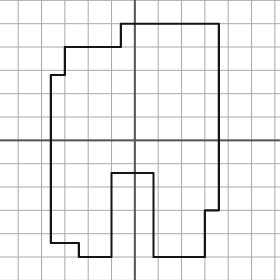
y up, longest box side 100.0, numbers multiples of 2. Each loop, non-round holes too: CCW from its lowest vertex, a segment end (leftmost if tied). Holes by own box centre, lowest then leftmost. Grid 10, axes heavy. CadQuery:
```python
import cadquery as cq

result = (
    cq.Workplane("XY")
    .moveTo(-24.0, -50.0)
    .lineTo(-10.0, -50.0)
    .lineTo(-10.0, -14.0)
    .lineTo(8.0, -14.0)
    .lineTo(8.0, -50.0)
    .lineTo(30.0, -50.0)
    .lineTo(30.0, -30.0)
    .lineTo(36.0, -30.0)
    .lineTo(36.0, 50.0)
    .lineTo(-6.0, 50.0)
    .lineTo(-6.0, 40.0)
    .lineTo(-30.0, 40.0)
    .lineTo(-30.0, 28.0)
    .lineTo(-36.0, 28.0)
    .lineTo(-36.0, -44.0)
    .lineTo(-24.0, -44.0)
    .close()
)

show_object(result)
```